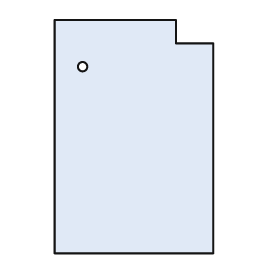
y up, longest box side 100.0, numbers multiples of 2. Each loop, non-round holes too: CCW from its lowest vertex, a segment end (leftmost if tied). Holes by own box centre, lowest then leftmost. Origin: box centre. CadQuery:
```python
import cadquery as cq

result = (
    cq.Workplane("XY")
    .moveTo(-34.0, -50.0)
    .lineTo(34.0, -50.0)
    .lineTo(34.0, 40.0)
    .lineTo(18.0, 40.0)
    .lineTo(18.0, 50.0)
    .lineTo(-34.0, 50.0)
    .close()
    .moveTo(-22.0, 30.0)
    .circle(2.0)
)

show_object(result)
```